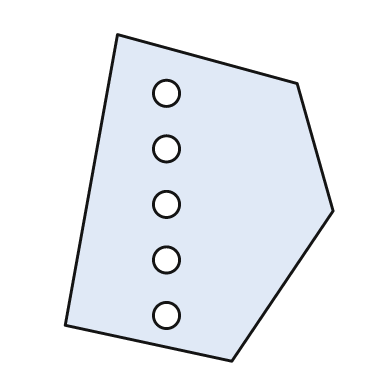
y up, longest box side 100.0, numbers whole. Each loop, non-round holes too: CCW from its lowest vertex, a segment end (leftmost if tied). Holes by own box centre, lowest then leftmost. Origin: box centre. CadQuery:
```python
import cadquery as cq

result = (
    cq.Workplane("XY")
    .moveTo(10.0, -50.0)
    .lineTo(41.0, -4.0)
    .lineTo(30.0, 35.0)
    .lineTo(-25.0, 50.0)
    .lineTo(-41.0, -39.0)
    .close()
    .moveTo(-10.0, -36.0)
    .circle(4.0)
    .moveTo(-10.0, -19.0)
    .circle(4.0)
    .moveTo(-10.0, -2.0)
    .circle(4.0)
    .moveTo(-10.0, 15.0)
    .circle(4.0)
    .moveTo(-10.0, 32.0)
    .circle(4.0)
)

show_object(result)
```